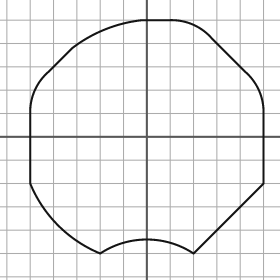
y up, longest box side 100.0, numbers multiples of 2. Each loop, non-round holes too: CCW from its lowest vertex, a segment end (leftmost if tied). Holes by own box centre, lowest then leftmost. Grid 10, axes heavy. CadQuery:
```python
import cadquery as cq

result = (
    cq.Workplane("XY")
    .moveTo(-20.0, -50.0)
    .threePointArc((0.0, -44.0), (20.0, -50.0))
    .lineTo(50.0, -20.0)
    .lineTo(50.0, 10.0)
    .threePointArc((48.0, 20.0), (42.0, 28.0))
    .lineTo(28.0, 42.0)
    .threePointArc((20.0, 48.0), (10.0, 50.0))
    .lineTo(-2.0, 50.0)
    .threePointArc((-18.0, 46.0), (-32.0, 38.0))
    .lineTo(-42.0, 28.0)
    .threePointArc((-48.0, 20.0), (-50.0, 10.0))
    .lineTo(-50.0, -20.0)
    .threePointArc((-38.0, -38.0), (-20.0, -50.0))
    .close()
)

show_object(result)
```